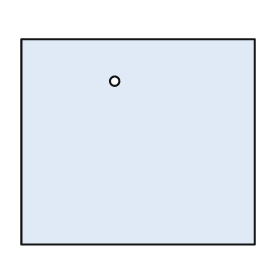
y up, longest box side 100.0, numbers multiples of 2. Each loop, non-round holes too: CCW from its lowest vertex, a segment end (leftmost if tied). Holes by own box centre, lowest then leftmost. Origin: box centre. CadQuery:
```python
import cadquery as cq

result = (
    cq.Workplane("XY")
    .moveTo(-50.0, -44.0)
    .lineTo(50.0, -44.0)
    .lineTo(50.0, 44.0)
    .lineTo(-50.0, 44.0)
    .close()
    .moveTo(-10.0, 26.0)
    .circle(2.0)
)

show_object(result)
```